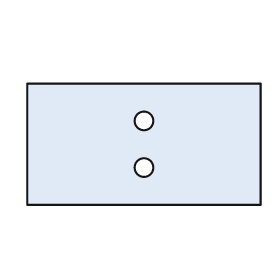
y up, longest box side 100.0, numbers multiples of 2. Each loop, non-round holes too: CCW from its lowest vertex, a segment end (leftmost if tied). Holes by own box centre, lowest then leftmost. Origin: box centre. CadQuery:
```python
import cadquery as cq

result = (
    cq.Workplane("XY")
    .moveTo(-50.0, -26.0)
    .lineTo(50.0, -26.0)
    .lineTo(50.0, 26.0)
    .lineTo(-50.0, 26.0)
    .close()
    .moveTo(0.0, -10.0)
    .circle(4.0)
    .moveTo(0.0, 10.0)
    .circle(4.0)
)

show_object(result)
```